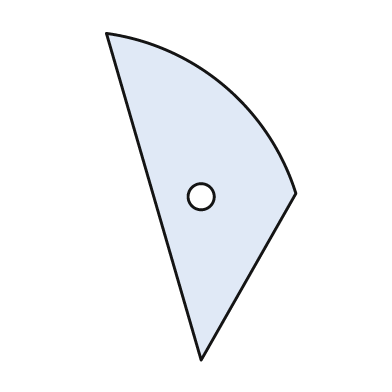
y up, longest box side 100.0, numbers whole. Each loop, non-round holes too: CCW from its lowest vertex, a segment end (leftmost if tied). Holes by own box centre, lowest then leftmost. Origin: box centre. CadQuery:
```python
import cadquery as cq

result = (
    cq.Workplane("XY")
    .moveTo(0.0, -50.0)
    .lineTo(29.0, 1.0)
    .threePointArc((7.0, 34.0), (-29.0, 50.0))
    .close()
    .moveTo(0.0, 0.0)
    .circle(4.0)
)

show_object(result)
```